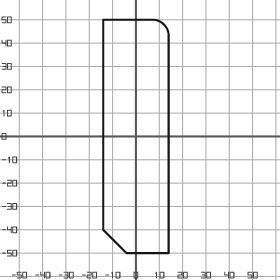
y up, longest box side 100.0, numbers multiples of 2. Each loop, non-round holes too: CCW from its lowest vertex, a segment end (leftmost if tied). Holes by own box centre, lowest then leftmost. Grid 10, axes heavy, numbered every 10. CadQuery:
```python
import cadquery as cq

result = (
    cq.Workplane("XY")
    .moveTo(-4.0, -50.0)
    .lineTo(14.0, -50.0)
    .lineTo(14.0, 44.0)
    .threePointArc((12.0, 48.0), (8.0, 50.0))
    .lineTo(-14.0, 50.0)
    .lineTo(-14.0, -40.0)
    .close()
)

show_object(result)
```